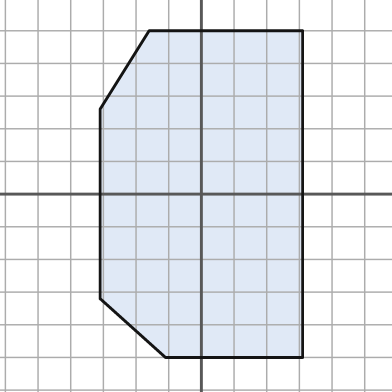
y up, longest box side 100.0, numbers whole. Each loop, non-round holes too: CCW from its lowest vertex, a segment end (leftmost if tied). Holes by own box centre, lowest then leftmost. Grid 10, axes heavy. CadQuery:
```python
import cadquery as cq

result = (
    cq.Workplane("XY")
    .moveTo(-11.0, -50.0)
    .lineTo(31.0, -50.0)
    .lineTo(31.0, 50.0)
    .lineTo(-16.0, 50.0)
    .lineTo(-31.0, 26.0)
    .lineTo(-31.0, -32.0)
    .close()
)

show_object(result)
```